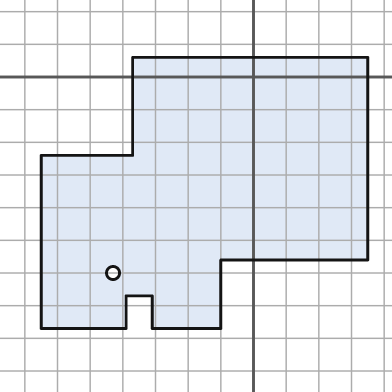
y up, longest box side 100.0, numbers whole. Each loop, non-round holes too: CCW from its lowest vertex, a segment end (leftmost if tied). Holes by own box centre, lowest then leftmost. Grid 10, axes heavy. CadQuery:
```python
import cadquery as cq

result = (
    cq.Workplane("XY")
    .moveTo(-65.0, -77.0)
    .lineTo(-39.0, -77.0)
    .lineTo(-39.0, -67.0)
    .lineTo(-31.0, -67.0)
    .lineTo(-31.0, -77.0)
    .lineTo(-10.0, -77.0)
    .lineTo(-10.0, -56.0)
    .lineTo(35.0, -56.0)
    .lineTo(35.0, 6.0)
    .lineTo(-37.0, 6.0)
    .lineTo(-37.0, -24.0)
    .lineTo(-65.0, -24.0)
    .close()
    .moveTo(-43.0, -60.0)
    .circle(2.0)
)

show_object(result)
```